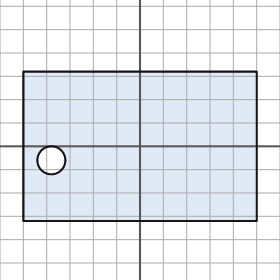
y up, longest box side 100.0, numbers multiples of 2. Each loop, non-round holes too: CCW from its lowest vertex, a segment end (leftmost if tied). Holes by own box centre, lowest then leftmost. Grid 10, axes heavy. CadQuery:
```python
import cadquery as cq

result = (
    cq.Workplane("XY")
    .moveTo(-50.0, -32.0)
    .lineTo(50.0, -32.0)
    .lineTo(50.0, 32.0)
    .lineTo(-50.0, 32.0)
    .close()
    .moveTo(-38.0, -6.0)
    .circle(6.0)
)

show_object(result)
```